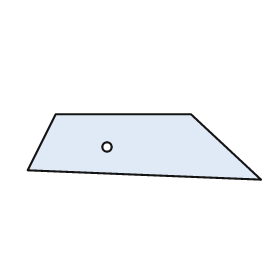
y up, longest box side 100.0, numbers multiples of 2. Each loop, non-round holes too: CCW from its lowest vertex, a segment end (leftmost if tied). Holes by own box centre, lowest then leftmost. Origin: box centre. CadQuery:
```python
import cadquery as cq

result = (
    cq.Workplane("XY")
    .moveTo(50.0, -14.0)
    .lineTo(20.0, 14.0)
    .lineTo(-38.0, 14.0)
    .lineTo(-50.0, -10.0)
    .close()
    .moveTo(-16.0, 0.0)
    .circle(2.0)
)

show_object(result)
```